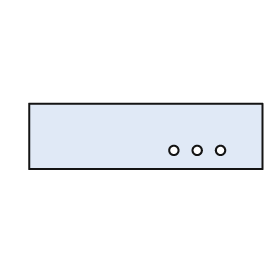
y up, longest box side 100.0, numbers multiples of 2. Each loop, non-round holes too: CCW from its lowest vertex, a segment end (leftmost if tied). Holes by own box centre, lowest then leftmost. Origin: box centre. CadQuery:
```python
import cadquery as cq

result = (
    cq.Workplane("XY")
    .moveTo(-50.0, -14.0)
    .lineTo(50.0, -14.0)
    .lineTo(50.0, 14.0)
    .lineTo(-50.0, 14.0)
    .close()
    .moveTo(12.0, -6.0)
    .circle(2.0)
    .moveTo(22.0, -6.0)
    .circle(2.0)
    .moveTo(32.0, -6.0)
    .circle(2.0)
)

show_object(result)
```